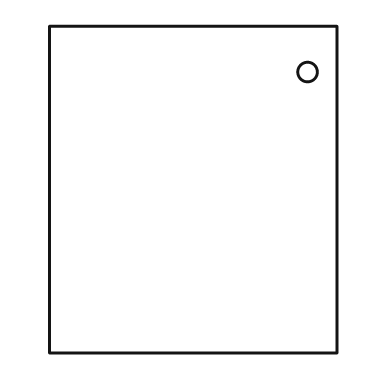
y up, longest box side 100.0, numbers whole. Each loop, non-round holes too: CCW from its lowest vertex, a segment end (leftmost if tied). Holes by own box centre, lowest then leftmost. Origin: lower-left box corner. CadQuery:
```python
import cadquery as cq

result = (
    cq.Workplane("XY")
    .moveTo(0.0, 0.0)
    .lineTo(88.0, 0.0)
    .lineTo(88.0, 100.0)
    .lineTo(0.0, 100.0)
    .close()
    .moveTo(79.0, 86.0)
    .circle(3.0)
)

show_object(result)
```